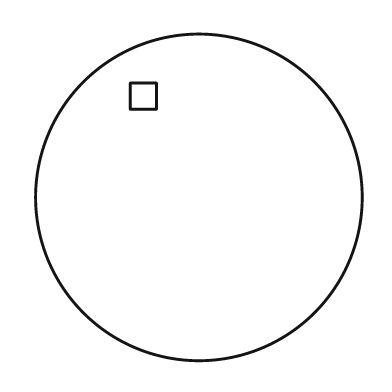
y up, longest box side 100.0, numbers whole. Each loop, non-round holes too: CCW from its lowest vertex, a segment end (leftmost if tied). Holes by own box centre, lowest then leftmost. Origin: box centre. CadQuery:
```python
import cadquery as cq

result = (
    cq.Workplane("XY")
    .moveTo(0.0, 0.0)
    .circle(50.0)
    .moveTo(-21.0, 27.0)
    .lineTo(-13.0, 27.0)
    .lineTo(-13.0, 35.0)
    .lineTo(-21.0, 35.0)
    .close()
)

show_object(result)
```